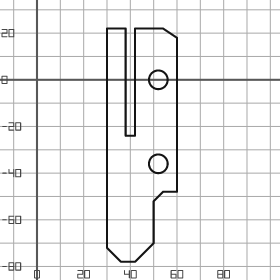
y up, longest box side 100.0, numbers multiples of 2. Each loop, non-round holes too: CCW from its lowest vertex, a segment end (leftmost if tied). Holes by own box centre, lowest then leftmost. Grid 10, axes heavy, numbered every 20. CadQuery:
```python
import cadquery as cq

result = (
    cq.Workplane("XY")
    .moveTo(36.0, -78.0)
    .lineTo(42.0, -78.0)
    .lineTo(50.0, -70.0)
    .lineTo(50.0, -52.0)
    .lineTo(54.0, -48.0)
    .lineTo(60.0, -48.0)
    .lineTo(60.0, 18.0)
    .lineTo(54.0, 22.0)
    .lineTo(42.0, 22.0)
    .lineTo(42.0, -24.0)
    .lineTo(38.0, -24.0)
    .lineTo(38.0, 22.0)
    .lineTo(30.0, 22.0)
    .lineTo(30.0, -72.0)
    .close()
    .moveTo(52.0, -36.0)
    .circle(4.0)
    .moveTo(52.0, 0.0)
    .circle(4.0)
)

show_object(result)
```